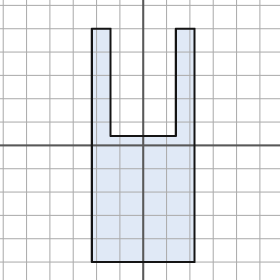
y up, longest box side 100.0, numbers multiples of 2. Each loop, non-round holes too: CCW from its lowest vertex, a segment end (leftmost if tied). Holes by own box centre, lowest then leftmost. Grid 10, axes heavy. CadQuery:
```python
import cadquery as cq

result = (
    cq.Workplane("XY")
    .moveTo(-22.0, -50.0)
    .lineTo(22.0, -50.0)
    .lineTo(22.0, 50.0)
    .lineTo(14.0, 50.0)
    .lineTo(14.0, 4.0)
    .lineTo(-14.0, 4.0)
    .lineTo(-14.0, 50.0)
    .lineTo(-22.0, 50.0)
    .close()
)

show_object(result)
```